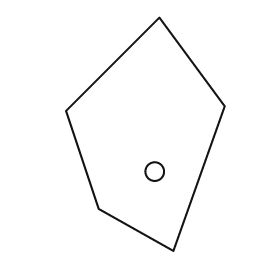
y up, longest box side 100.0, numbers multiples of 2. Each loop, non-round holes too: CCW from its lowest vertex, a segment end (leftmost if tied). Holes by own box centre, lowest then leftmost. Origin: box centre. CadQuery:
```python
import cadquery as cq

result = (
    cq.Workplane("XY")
    .moveTo(12.0, -50.0)
    .lineTo(34.0, 12.0)
    .lineTo(6.0, 50.0)
    .lineTo(-34.0, 10.0)
    .lineTo(-20.0, -32.0)
    .close()
    .moveTo(4.0, -16.0)
    .circle(4.0)
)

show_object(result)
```